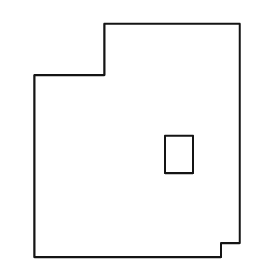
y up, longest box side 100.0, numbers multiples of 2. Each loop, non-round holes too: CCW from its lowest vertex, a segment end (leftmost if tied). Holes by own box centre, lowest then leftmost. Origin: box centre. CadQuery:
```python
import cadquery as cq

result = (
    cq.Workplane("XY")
    .moveTo(-44.0, -50.0)
    .lineTo(36.0, -50.0)
    .lineTo(36.0, -44.0)
    .lineTo(44.0, -44.0)
    .lineTo(44.0, 50.0)
    .lineTo(-14.0, 50.0)
    .lineTo(-14.0, 28.0)
    .lineTo(-44.0, 28.0)
    .close()
    .moveTo(12.0, -14.0)
    .lineTo(24.0, -14.0)
    .lineTo(24.0, 2.0)
    .lineTo(12.0, 2.0)
    .close()
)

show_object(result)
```